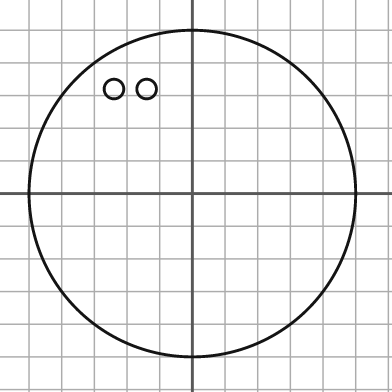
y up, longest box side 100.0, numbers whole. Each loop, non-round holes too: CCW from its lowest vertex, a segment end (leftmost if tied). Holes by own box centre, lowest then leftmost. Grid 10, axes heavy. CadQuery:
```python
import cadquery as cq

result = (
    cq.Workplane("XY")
    .moveTo(0.0, 0.0)
    .circle(50.0)
    .moveTo(-24.0, 32.0)
    .circle(3.0)
    .moveTo(-14.0, 32.0)
    .circle(3.0)
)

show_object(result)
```